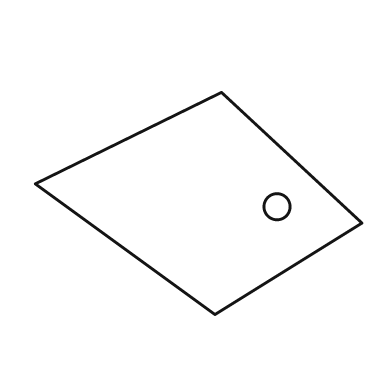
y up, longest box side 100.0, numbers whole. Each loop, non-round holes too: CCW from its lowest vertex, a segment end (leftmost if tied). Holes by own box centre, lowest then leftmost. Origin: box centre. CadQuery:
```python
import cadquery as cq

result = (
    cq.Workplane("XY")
    .moveTo(5.0, -34.0)
    .lineTo(50.0, -6.0)
    .lineTo(7.0, 34.0)
    .lineTo(-50.0, 6.0)
    .close()
    .moveTo(24.0, -1.0)
    .circle(4.0)
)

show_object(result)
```